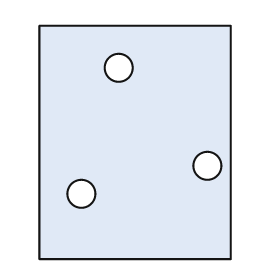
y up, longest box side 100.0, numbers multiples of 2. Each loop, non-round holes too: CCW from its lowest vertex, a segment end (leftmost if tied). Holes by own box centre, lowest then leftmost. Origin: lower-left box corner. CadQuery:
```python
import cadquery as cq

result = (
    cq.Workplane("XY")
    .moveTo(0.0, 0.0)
    .lineTo(82.0, 0.0)
    .lineTo(82.0, 100.0)
    .lineTo(0.0, 100.0)
    .close()
    .moveTo(18.0, 28.0)
    .circle(6.0)
    .moveTo(72.0, 40.0)
    .circle(6.0)
    .moveTo(34.0, 82.0)
    .circle(6.0)
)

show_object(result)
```